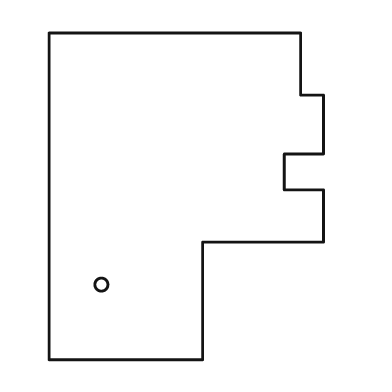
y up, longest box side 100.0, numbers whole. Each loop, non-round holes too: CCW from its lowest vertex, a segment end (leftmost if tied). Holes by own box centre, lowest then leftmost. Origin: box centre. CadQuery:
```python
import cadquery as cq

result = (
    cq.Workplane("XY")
    .moveTo(-42.0, -50.0)
    .lineTo(5.0, -50.0)
    .lineTo(5.0, -14.0)
    .lineTo(42.0, -14.0)
    .lineTo(42.0, 2.0)
    .lineTo(30.0, 2.0)
    .lineTo(30.0, 13.0)
    .lineTo(42.0, 13.0)
    .lineTo(42.0, 31.0)
    .lineTo(35.0, 31.0)
    .lineTo(35.0, 50.0)
    .lineTo(-42.0, 50.0)
    .close()
    .moveTo(-26.0, -27.0)
    .circle(2.0)
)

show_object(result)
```